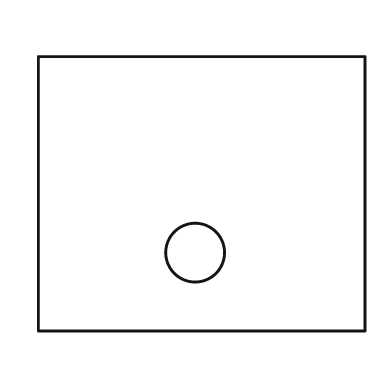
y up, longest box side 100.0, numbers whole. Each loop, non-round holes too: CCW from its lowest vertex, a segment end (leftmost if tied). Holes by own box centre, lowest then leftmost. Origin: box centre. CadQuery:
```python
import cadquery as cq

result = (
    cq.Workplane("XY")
    .moveTo(-50.0, -42.0)
    .lineTo(50.0, -42.0)
    .lineTo(50.0, 42.0)
    .lineTo(-50.0, 42.0)
    .close()
    .moveTo(-2.0, -18.0)
    .circle(9.0)
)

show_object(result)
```